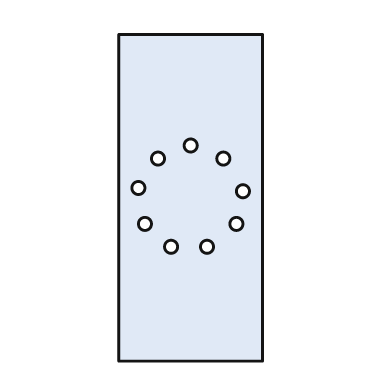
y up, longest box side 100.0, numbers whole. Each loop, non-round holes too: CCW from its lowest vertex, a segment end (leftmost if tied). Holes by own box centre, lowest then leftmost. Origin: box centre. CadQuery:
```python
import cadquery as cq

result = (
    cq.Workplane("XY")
    .moveTo(-22.0, -50.0)
    .lineTo(22.0, -50.0)
    .lineTo(22.0, 50.0)
    .lineTo(-22.0, 50.0)
    .close()
    .moveTo(-6.0, -15.0)
    .circle(2.0)
    .moveTo(5.0, -15.0)
    .circle(2.0)
    .moveTo(-14.0, -8.0)
    .circle(2.0)
    .moveTo(14.0, -8.0)
    .circle(2.0)
    .moveTo(16.0, 2.0)
    .circle(2.0)
    .moveTo(-16.0, 3.0)
    .circle(2.0)
    .moveTo(-10.0, 12.0)
    .circle(2.0)
    .moveTo(10.0, 12.0)
    .circle(2.0)
    .moveTo(0.0, 16.0)
    .circle(2.0)
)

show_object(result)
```